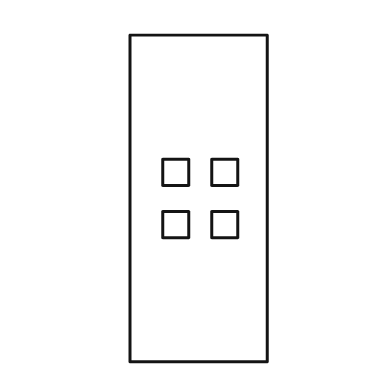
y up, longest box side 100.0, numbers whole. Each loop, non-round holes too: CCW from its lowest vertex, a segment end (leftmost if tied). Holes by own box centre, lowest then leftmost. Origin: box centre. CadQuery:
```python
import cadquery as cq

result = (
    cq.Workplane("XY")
    .moveTo(-21.0, -50.0)
    .lineTo(21.0, -50.0)
    .lineTo(21.0, 50.0)
    .lineTo(-21.0, 50.0)
    .close()
    .moveTo(-11.0, -12.0)
    .lineTo(-3.0, -12.0)
    .lineTo(-3.0, -4.0)
    .lineTo(-11.0, -4.0)
    .close()
    .moveTo(4.0, -12.0)
    .lineTo(12.0, -12.0)
    .lineTo(12.0, -4.0)
    .lineTo(4.0, -4.0)
    .close()
    .moveTo(-11.0, 4.0)
    .lineTo(-3.0, 4.0)
    .lineTo(-3.0, 12.0)
    .lineTo(-11.0, 12.0)
    .close()
    .moveTo(4.0, 4.0)
    .lineTo(12.0, 4.0)
    .lineTo(12.0, 12.0)
    .lineTo(4.0, 12.0)
    .close()
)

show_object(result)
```